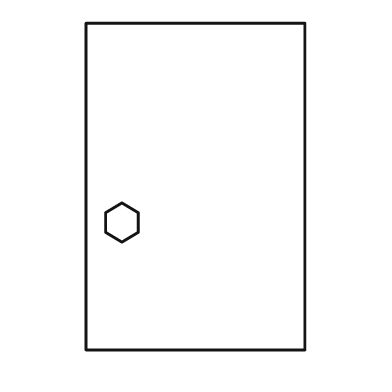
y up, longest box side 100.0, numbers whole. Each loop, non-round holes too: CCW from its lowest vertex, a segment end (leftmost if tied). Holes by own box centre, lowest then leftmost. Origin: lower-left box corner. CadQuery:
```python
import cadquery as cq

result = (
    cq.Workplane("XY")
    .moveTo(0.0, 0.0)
    .lineTo(67.0, 0.0)
    .lineTo(67.0, 100.0)
    .lineTo(0.0, 100.0)
    .close()
    .moveTo(11.0, 33.0)
    .lineTo(16.0, 36.0)
    .lineTo(16.0, 42.0)
    .lineTo(11.0, 45.0)
    .lineTo(6.0, 42.0)
    .lineTo(6.0, 36.0)
    .close()
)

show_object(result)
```